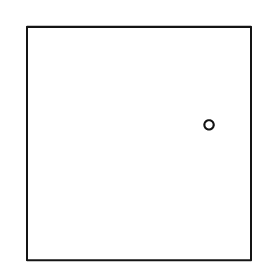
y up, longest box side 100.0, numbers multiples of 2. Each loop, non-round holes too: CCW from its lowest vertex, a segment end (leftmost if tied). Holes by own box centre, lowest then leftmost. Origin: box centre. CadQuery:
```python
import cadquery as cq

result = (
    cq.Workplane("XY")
    .moveTo(-48.0, -50.0)
    .lineTo(48.0, -50.0)
    .lineTo(48.0, 50.0)
    .lineTo(-48.0, 50.0)
    .close()
    .moveTo(30.0, 8.0)
    .circle(2.0)
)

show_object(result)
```